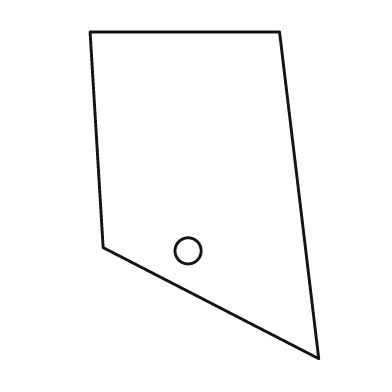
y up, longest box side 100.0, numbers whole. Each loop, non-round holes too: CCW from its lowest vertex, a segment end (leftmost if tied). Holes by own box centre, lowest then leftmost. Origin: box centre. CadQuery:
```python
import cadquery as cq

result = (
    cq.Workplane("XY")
    .moveTo(35.0, -50.0)
    .lineTo(23.0, 50.0)
    .lineTo(-35.0, 50.0)
    .lineTo(-31.0, -16.0)
    .close()
    .moveTo(-5.0, -17.0)
    .circle(4.0)
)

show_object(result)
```